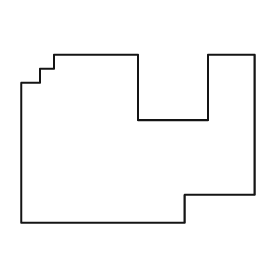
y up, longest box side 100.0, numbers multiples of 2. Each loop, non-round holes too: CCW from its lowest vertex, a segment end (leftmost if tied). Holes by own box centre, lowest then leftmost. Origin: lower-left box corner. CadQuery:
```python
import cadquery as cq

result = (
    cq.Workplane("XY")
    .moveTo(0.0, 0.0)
    .lineTo(70.0, 0.0)
    .lineTo(70.0, 12.0)
    .lineTo(100.0, 12.0)
    .lineTo(100.0, 72.0)
    .lineTo(80.0, 72.0)
    .lineTo(80.0, 44.0)
    .lineTo(50.0, 44.0)
    .lineTo(50.0, 72.0)
    .lineTo(14.0, 72.0)
    .lineTo(14.0, 66.0)
    .lineTo(8.0, 66.0)
    .lineTo(8.0, 60.0)
    .lineTo(0.0, 60.0)
    .close()
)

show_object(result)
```